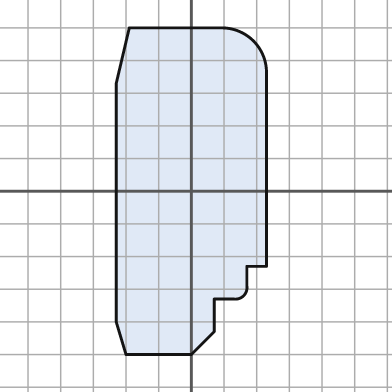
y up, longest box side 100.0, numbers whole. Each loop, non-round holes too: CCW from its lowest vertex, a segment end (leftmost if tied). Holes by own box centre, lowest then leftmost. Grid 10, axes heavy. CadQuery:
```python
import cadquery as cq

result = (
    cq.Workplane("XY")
    .moveTo(-20.0, -50.0)
    .lineTo(0.0, -50.0)
    .lineTo(7.0, -43.0)
    .lineTo(7.0, -33.0)
    .lineTo(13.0, -33.0)
    .threePointArc((16.0, -32.0), (17.0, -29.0))
    .lineTo(17.0, -23.0)
    .lineTo(23.0, -23.0)
    .lineTo(23.0, 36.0)
    .threePointArc((19.0, 46.0), (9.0, 50.0))
    .lineTo(-19.0, 50.0)
    .lineTo(-23.0, 33.0)
    .lineTo(-23.0, -40.0)
    .close()
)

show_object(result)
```